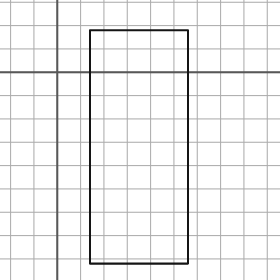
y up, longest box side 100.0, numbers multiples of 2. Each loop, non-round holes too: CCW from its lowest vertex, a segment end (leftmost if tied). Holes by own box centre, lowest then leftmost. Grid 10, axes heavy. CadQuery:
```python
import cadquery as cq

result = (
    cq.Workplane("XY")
    .moveTo(14.0, -82.0)
    .lineTo(56.0, -82.0)
    .lineTo(56.0, 18.0)
    .lineTo(14.0, 18.0)
    .close()
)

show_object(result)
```